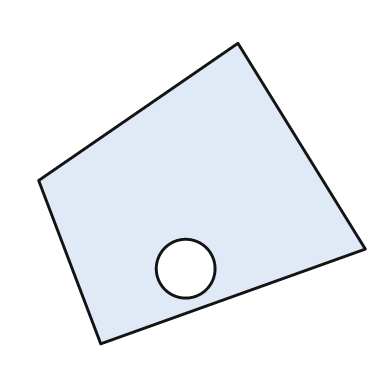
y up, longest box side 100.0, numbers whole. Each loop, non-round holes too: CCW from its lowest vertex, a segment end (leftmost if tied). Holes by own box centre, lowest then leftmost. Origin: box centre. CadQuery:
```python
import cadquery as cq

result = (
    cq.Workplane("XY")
    .moveTo(-31.0, -46.0)
    .lineTo(50.0, -17.0)
    .lineTo(11.0, 46.0)
    .lineTo(-50.0, 4.0)
    .close()
    .moveTo(-5.0, -23.0)
    .circle(9.0)
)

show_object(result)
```